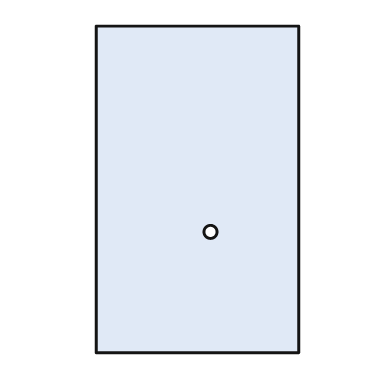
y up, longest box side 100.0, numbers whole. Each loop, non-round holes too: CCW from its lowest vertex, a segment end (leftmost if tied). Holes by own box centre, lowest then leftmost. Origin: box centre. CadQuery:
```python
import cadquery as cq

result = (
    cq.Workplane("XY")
    .moveTo(-31.0, -50.0)
    .lineTo(31.0, -50.0)
    .lineTo(31.0, 50.0)
    .lineTo(-31.0, 50.0)
    .close()
    .moveTo(4.0, -13.0)
    .circle(2.0)
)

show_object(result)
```